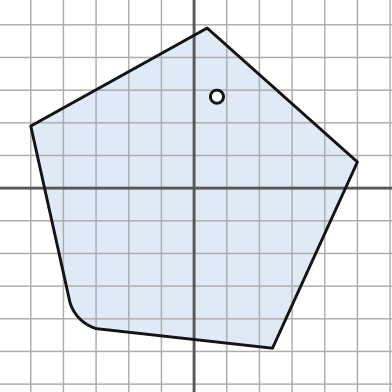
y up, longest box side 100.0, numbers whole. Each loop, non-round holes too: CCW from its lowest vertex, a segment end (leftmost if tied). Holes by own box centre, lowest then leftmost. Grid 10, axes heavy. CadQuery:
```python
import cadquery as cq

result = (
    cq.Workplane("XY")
    .moveTo(24.0, -49.0)
    .lineTo(50.0, 8.0)
    .lineTo(4.0, 49.0)
    .lineTo(-50.0, 19.0)
    .lineTo(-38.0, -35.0)
    .threePointArc((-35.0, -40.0), (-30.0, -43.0))
    .close()
    .moveTo(7.0, 28.0)
    .circle(2.0)
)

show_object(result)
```